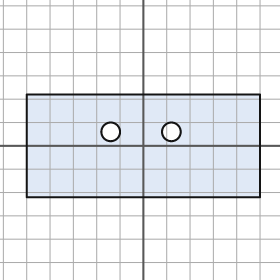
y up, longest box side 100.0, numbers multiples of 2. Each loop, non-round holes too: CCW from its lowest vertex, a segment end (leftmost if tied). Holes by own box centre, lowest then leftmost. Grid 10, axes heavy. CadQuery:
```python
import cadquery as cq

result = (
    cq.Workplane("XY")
    .moveTo(-50.0, -22.0)
    .lineTo(50.0, -22.0)
    .lineTo(50.0, 22.0)
    .lineTo(-50.0, 22.0)
    .close()
    .moveTo(-14.0, 6.0)
    .circle(4.0)
    .moveTo(12.0, 6.0)
    .circle(4.0)
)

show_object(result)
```